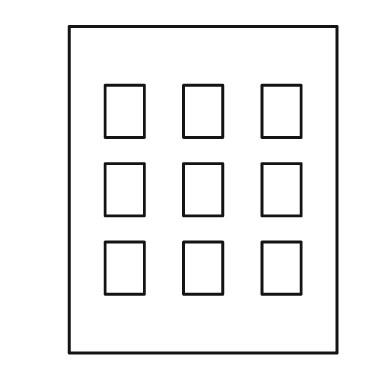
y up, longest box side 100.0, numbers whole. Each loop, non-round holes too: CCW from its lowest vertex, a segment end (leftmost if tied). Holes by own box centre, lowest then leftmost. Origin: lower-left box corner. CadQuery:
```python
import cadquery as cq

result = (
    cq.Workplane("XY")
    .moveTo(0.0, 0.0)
    .lineTo(82.0, 0.0)
    .lineTo(82.0, 100.0)
    .lineTo(0.0, 100.0)
    .close()
    .moveTo(11.0, 18.0)
    .lineTo(23.0, 18.0)
    .lineTo(23.0, 34.0)
    .lineTo(11.0, 34.0)
    .close()
    .moveTo(35.0, 18.0)
    .lineTo(47.0, 18.0)
    .lineTo(47.0, 34.0)
    .lineTo(35.0, 34.0)
    .close()
    .moveTo(59.0, 18.0)
    .lineTo(71.0, 18.0)
    .lineTo(71.0, 34.0)
    .lineTo(59.0, 34.0)
    .close()
    .moveTo(11.0, 42.0)
    .lineTo(23.0, 42.0)
    .lineTo(23.0, 58.0)
    .lineTo(11.0, 58.0)
    .close()
    .moveTo(35.0, 42.0)
    .lineTo(47.0, 42.0)
    .lineTo(47.0, 58.0)
    .lineTo(35.0, 58.0)
    .close()
    .moveTo(59.0, 42.0)
    .lineTo(71.0, 42.0)
    .lineTo(71.0, 58.0)
    .lineTo(59.0, 58.0)
    .close()
    .moveTo(11.0, 66.0)
    .lineTo(23.0, 66.0)
    .lineTo(23.0, 82.0)
    .lineTo(11.0, 82.0)
    .close()
    .moveTo(35.0, 66.0)
    .lineTo(47.0, 66.0)
    .lineTo(47.0, 82.0)
    .lineTo(35.0, 82.0)
    .close()
    .moveTo(59.0, 66.0)
    .lineTo(71.0, 66.0)
    .lineTo(71.0, 82.0)
    .lineTo(59.0, 82.0)
    .close()
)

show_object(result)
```